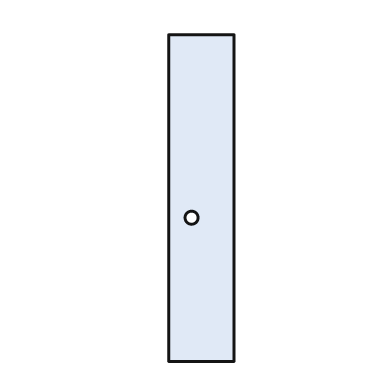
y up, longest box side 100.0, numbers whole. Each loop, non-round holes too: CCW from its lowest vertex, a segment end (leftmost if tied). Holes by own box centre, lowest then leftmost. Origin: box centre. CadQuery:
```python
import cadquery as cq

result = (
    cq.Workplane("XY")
    .moveTo(-10.0, -50.0)
    .lineTo(10.0, -50.0)
    .lineTo(10.0, 50.0)
    .lineTo(-10.0, 50.0)
    .close()
    .moveTo(-3.0, -6.0)
    .circle(2.0)
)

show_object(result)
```